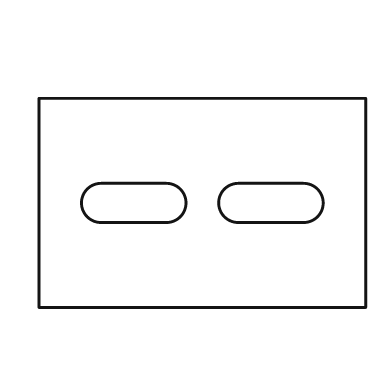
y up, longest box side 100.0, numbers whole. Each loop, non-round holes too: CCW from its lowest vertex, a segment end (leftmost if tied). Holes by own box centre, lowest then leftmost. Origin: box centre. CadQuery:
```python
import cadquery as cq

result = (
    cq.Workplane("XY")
    .moveTo(-50.0, -32.0)
    .lineTo(50.0, -32.0)
    .lineTo(50.0, 32.0)
    .lineTo(-50.0, 32.0)
    .close()
    .moveTo(-31.0, -6.0)
    .lineTo(-11.0, -6.0)
    .threePointArc((-5.0, 0.0), (-11.0, 6.0))
    .lineTo(-31.0, 6.0)
    .threePointArc((-37.0, 0.0), (-31.0, -6.0))
    .close()
    .moveTo(11.0, -6.0)
    .lineTo(31.0, -6.0)
    .threePointArc((37.0, 0.0), (31.0, 6.0))
    .lineTo(11.0, 6.0)
    .threePointArc((5.0, 0.0), (11.0, -6.0))
    .close()
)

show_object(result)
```